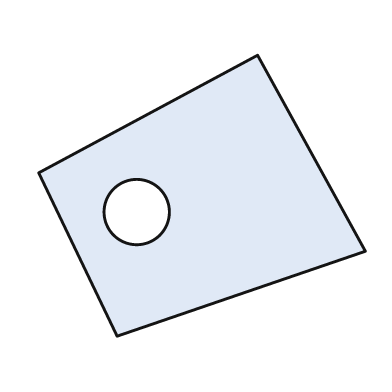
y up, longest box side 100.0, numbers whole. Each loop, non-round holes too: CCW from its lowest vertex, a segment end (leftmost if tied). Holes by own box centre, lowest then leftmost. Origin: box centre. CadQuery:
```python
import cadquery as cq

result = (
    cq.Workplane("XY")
    .moveTo(-26.0, -43.0)
    .lineTo(50.0, -17.0)
    .lineTo(17.0, 43.0)
    .lineTo(-50.0, 7.0)
    .close()
    .moveTo(-20.0, -5.0)
    .circle(10.0)
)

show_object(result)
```